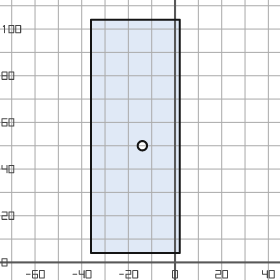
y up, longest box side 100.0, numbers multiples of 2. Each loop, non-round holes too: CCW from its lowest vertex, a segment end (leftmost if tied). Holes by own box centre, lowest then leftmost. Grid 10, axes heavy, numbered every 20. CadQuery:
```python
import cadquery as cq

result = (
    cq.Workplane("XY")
    .moveTo(-36.0, 4.0)
    .lineTo(2.0, 4.0)
    .lineTo(2.0, 104.0)
    .lineTo(-36.0, 104.0)
    .close()
    .moveTo(-14.0, 50.0)
    .circle(2.0)
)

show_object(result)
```